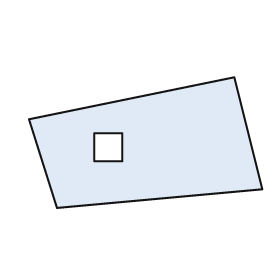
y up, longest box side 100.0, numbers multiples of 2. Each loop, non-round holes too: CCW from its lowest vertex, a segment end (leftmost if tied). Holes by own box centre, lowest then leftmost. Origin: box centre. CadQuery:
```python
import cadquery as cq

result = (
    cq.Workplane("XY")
    .moveTo(-38.0, -28.0)
    .lineTo(50.0, -20.0)
    .lineTo(38.0, 28.0)
    .lineTo(-50.0, 10.0)
    .close()
    .moveTo(-22.0, -8.0)
    .lineTo(-10.0, -8.0)
    .lineTo(-10.0, 4.0)
    .lineTo(-22.0, 4.0)
    .close()
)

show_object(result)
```